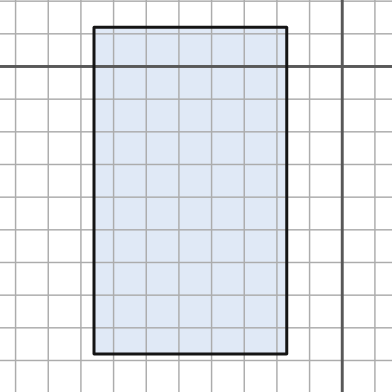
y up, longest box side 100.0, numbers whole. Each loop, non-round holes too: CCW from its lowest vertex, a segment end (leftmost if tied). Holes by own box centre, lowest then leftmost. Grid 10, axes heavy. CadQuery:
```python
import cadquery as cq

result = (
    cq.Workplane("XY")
    .moveTo(-76.0, -88.0)
    .lineTo(-17.0, -88.0)
    .lineTo(-17.0, 12.0)
    .lineTo(-76.0, 12.0)
    .close()
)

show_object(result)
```